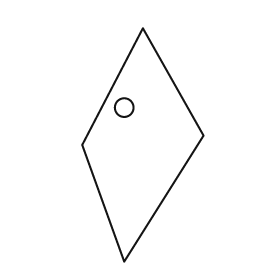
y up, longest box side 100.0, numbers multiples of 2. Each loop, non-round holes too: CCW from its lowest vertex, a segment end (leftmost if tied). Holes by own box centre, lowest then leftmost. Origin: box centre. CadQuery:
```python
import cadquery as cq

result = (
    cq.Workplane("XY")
    .moveTo(-8.0, -50.0)
    .lineTo(26.0, 4.0)
    .lineTo(0.0, 50.0)
    .lineTo(-26.0, 0.0)
    .close()
    .moveTo(-8.0, 16.0)
    .circle(4.0)
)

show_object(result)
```